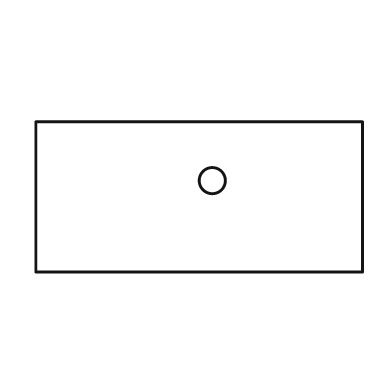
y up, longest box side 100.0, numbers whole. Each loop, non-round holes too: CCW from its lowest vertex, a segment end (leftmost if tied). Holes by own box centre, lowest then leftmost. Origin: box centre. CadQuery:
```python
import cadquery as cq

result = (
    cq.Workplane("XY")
    .moveTo(-50.0, -23.0)
    .lineTo(50.0, -23.0)
    .lineTo(50.0, 23.0)
    .lineTo(-50.0, 23.0)
    .close()
    .moveTo(4.0, 5.0)
    .circle(4.0)
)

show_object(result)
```